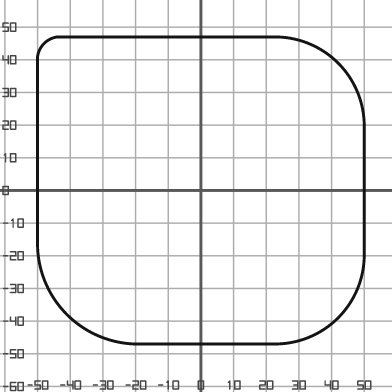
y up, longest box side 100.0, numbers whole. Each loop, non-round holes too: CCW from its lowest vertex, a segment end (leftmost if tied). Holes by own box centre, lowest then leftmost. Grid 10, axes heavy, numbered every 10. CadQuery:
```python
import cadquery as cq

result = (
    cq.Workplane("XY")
    .moveTo(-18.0, -47.0)
    .lineTo(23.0, -47.0)
    .threePointArc((42.0, -39.0), (50.0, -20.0))
    .lineTo(50.0, 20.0)
    .threePointArc((42.0, 39.0), (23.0, 47.0))
    .lineTo(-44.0, 47.0)
    .threePointArc((-48.0, 45.0), (-50.0, 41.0))
    .lineTo(-50.0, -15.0)
    .threePointArc((-41.0, -38.0), (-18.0, -47.0))
    .close()
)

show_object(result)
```